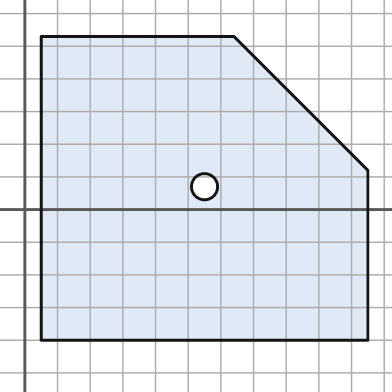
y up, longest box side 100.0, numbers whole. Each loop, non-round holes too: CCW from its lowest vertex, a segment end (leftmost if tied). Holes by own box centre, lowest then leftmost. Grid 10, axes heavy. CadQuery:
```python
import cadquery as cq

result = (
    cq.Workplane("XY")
    .moveTo(5.0, -40.0)
    .lineTo(105.0, -40.0)
    .lineTo(105.0, 12.0)
    .lineTo(64.0, 53.0)
    .lineTo(5.0, 53.0)
    .close()
    .moveTo(55.0, 7.0)
    .circle(4.0)
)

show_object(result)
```